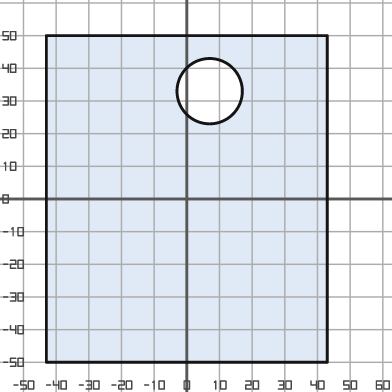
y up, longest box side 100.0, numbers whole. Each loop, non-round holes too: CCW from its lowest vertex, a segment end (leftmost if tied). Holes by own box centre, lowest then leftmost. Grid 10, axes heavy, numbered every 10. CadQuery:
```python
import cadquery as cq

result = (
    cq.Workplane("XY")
    .moveTo(-43.0, -50.0)
    .lineTo(43.0, -50.0)
    .lineTo(43.0, 50.0)
    .lineTo(-43.0, 50.0)
    .close()
    .moveTo(7.0, 33.0)
    .circle(10.0)
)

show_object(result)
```